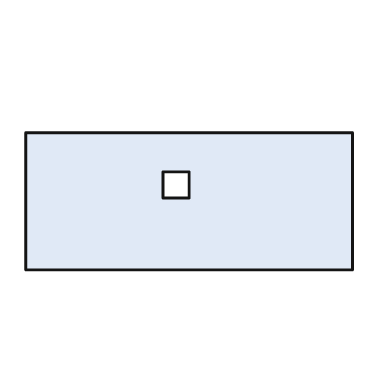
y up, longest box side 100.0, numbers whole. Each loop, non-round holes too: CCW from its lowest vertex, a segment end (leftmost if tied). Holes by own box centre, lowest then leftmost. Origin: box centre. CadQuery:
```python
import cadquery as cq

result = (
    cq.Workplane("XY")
    .moveTo(-50.0, -21.0)
    .lineTo(50.0, -21.0)
    .lineTo(50.0, 21.0)
    .lineTo(-50.0, 21.0)
    .close()
    .moveTo(-8.0, 1.0)
    .lineTo(0.0, 1.0)
    .lineTo(0.0, 9.0)
    .lineTo(-8.0, 9.0)
    .close()
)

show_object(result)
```